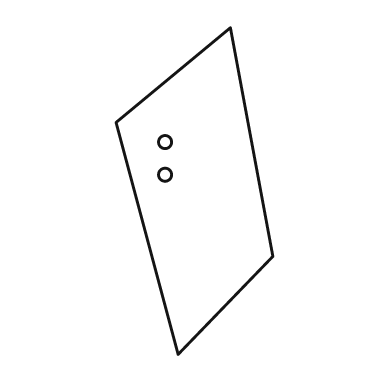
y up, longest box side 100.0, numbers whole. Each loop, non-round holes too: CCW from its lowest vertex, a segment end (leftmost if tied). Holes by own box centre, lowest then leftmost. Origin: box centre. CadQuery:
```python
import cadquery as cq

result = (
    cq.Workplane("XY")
    .moveTo(-5.0, -50.0)
    .lineTo(24.0, -20.0)
    .lineTo(11.0, 50.0)
    .lineTo(-24.0, 21.0)
    .close()
    .moveTo(-9.0, 5.0)
    .circle(2.0)
    .moveTo(-9.0, 15.0)
    .circle(2.0)
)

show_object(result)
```